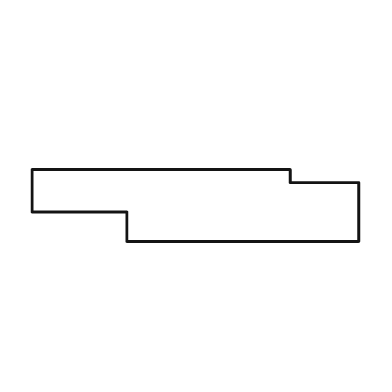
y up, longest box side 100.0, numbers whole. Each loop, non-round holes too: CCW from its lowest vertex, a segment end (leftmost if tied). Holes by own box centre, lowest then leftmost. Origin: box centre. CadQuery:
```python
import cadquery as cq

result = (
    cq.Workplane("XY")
    .moveTo(-21.0, -11.0)
    .lineTo(50.0, -11.0)
    .lineTo(50.0, 7.0)
    .lineTo(29.0, 7.0)
    .lineTo(29.0, 11.0)
    .lineTo(-50.0, 11.0)
    .lineTo(-50.0, -2.0)
    .lineTo(-21.0, -2.0)
    .close()
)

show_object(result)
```